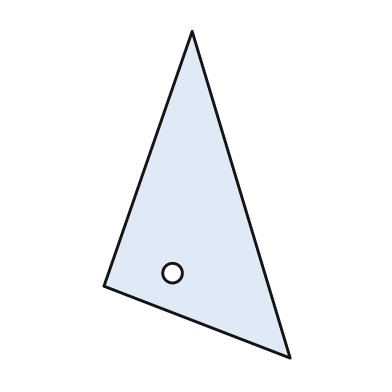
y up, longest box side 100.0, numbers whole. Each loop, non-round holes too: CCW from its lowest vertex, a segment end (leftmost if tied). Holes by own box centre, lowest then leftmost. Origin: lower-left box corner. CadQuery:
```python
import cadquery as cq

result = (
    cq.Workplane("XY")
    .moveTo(57.0, 0.0)
    .lineTo(27.0, 100.0)
    .lineTo(0.0, 22.0)
    .close()
    .moveTo(21.0, 26.0)
    .circle(3.0)
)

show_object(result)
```